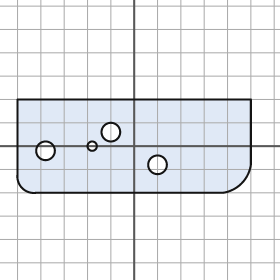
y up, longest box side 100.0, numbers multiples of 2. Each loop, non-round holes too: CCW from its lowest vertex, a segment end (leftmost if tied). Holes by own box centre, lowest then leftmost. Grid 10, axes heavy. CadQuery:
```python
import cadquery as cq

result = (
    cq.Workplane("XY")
    .moveTo(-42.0, -20.0)
    .lineTo(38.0, -20.0)
    .threePointArc((46.0, -16.0), (50.0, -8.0))
    .lineTo(50.0, 20.0)
    .lineTo(-50.0, 20.0)
    .lineTo(-50.0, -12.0)
    .threePointArc((-48.0, -18.0), (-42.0, -20.0))
    .close()
    .moveTo(10.0, -8.0)
    .circle(4.0)
    .moveTo(-38.0, -2.0)
    .circle(4.0)
    .moveTo(-18.0, 0.0)
    .circle(2.0)
    .moveTo(-10.0, 6.0)
    .circle(4.0)
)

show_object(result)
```